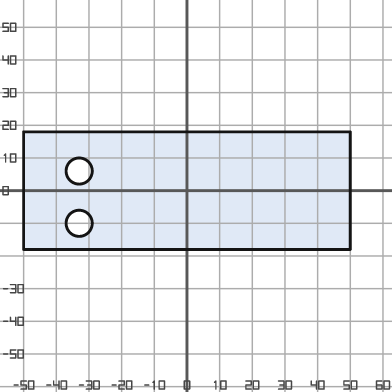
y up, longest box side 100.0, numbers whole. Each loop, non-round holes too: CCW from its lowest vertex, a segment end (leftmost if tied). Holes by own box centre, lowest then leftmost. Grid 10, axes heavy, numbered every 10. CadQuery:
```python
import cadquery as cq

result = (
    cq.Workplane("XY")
    .moveTo(-50.0, -18.0)
    .lineTo(50.0, -18.0)
    .lineTo(50.0, 18.0)
    .lineTo(-50.0, 18.0)
    .close()
    .moveTo(-33.0, -10.0)
    .circle(4.0)
    .moveTo(-33.0, 6.0)
    .circle(4.0)
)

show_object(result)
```